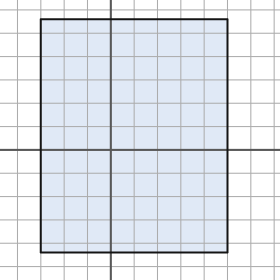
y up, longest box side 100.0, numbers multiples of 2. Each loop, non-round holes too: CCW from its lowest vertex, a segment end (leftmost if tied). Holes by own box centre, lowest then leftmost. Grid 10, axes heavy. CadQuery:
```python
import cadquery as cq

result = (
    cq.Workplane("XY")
    .moveTo(-30.0, -44.0)
    .lineTo(50.0, -44.0)
    .lineTo(50.0, 56.0)
    .lineTo(-30.0, 56.0)
    .close()
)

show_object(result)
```